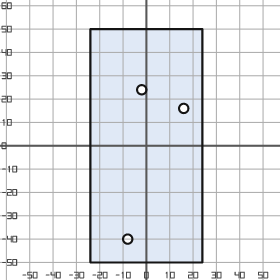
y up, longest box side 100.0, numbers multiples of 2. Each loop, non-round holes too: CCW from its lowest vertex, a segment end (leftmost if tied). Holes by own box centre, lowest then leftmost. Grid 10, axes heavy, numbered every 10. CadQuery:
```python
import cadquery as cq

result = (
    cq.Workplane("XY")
    .moveTo(-24.0, -50.0)
    .lineTo(24.0, -50.0)
    .lineTo(24.0, 50.0)
    .lineTo(-24.0, 50.0)
    .close()
    .moveTo(-8.0, -40.0)
    .circle(2.0)
    .moveTo(16.0, 16.0)
    .circle(2.0)
    .moveTo(-2.0, 24.0)
    .circle(2.0)
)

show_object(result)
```